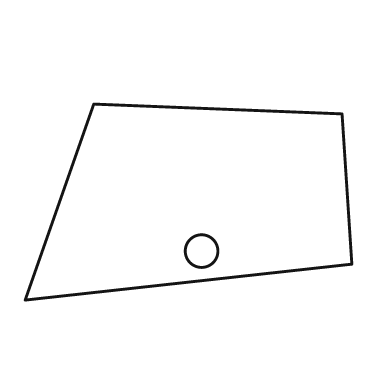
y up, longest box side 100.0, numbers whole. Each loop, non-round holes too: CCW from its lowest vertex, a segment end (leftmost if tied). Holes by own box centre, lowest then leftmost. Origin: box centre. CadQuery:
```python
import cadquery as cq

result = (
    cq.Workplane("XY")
    .moveTo(-50.0, -30.0)
    .lineTo(50.0, -19.0)
    .lineTo(47.0, 27.0)
    .lineTo(-29.0, 30.0)
    .close()
    .moveTo(4.0, -15.0)
    .circle(5.0)
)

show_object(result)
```